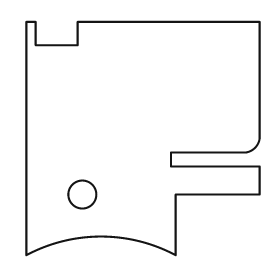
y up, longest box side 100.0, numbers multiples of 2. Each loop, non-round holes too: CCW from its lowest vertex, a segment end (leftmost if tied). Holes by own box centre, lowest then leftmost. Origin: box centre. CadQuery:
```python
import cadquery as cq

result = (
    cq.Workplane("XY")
    .moveTo(-50.0, -50.0)
    .threePointArc((-18.0, -42.0), (14.0, -50.0))
    .lineTo(14.0, -24.0)
    .lineTo(50.0, -24.0)
    .lineTo(50.0, -12.0)
    .lineTo(12.0, -12.0)
    .lineTo(12.0, -6.0)
    .lineTo(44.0, -6.0)
    .threePointArc((48.0, -4.0), (50.0, 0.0))
    .lineTo(50.0, 50.0)
    .lineTo(-28.0, 50.0)
    .lineTo(-28.0, 40.0)
    .lineTo(-46.0, 40.0)
    .lineTo(-46.0, 50.0)
    .lineTo(-50.0, 50.0)
    .close()
    .moveTo(-26.0, -24.0)
    .circle(6.0)
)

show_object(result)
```